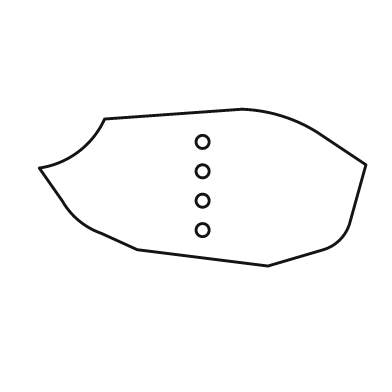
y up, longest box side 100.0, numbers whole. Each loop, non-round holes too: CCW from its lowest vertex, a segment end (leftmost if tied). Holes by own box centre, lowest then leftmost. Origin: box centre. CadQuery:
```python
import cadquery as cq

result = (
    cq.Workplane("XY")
    .moveTo(20.0, -24.0)
    .lineTo(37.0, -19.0)
    .threePointArc((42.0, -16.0), (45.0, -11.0))
    .lineTo(50.0, 7.0)
    .lineTo(35.0, 17.0)
    .threePointArc((24.0, 22.0), (12.0, 24.0))
    .lineTo(-30.0, 21.0)
    .threePointArc((-38.0, 11.0), (-50.0, 6.0))
    .lineTo(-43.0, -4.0)
    .threePointArc((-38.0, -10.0), (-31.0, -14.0))
    .lineTo(-20.0, -19.0)
    .close()
    .moveTo(0.0, -13.0)
    .circle(2.0)
    .moveTo(0.0, -4.0)
    .circle(2.0)
    .moveTo(0.0, 5.0)
    .circle(2.0)
    .moveTo(0.0, 14.0)
    .circle(2.0)
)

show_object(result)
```